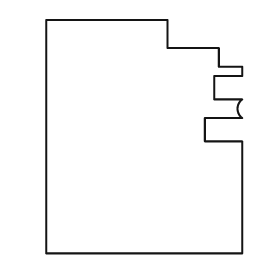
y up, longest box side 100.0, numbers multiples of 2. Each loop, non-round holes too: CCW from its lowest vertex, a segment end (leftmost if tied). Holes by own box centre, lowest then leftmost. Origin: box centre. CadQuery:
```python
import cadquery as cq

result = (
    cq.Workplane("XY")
    .moveTo(-42.0, -50.0)
    .lineTo(42.0, -50.0)
    .lineTo(42.0, -2.0)
    .lineTo(26.0, -2.0)
    .lineTo(26.0, 8.0)
    .lineTo(42.0, 8.0)
    .threePointArc((40.0, 12.0), (42.0, 16.0))
    .lineTo(30.0, 16.0)
    .lineTo(30.0, 26.0)
    .lineTo(42.0, 26.0)
    .lineTo(42.0, 30.0)
    .lineTo(32.0, 30.0)
    .lineTo(32.0, 38.0)
    .lineTo(10.0, 38.0)
    .lineTo(10.0, 50.0)
    .lineTo(-42.0, 50.0)
    .close()
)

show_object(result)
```